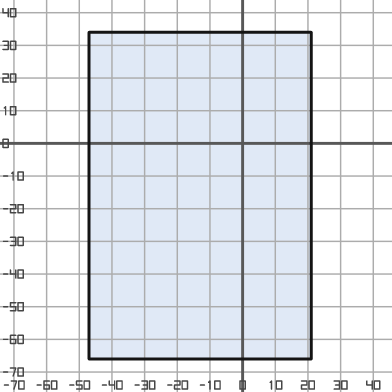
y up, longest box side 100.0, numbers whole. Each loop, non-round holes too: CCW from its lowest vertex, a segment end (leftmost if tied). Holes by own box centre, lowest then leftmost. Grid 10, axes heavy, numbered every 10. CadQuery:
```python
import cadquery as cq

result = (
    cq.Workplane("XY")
    .moveTo(-47.0, -66.0)
    .lineTo(21.0, -66.0)
    .lineTo(21.0, 34.0)
    .lineTo(-47.0, 34.0)
    .close()
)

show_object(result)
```